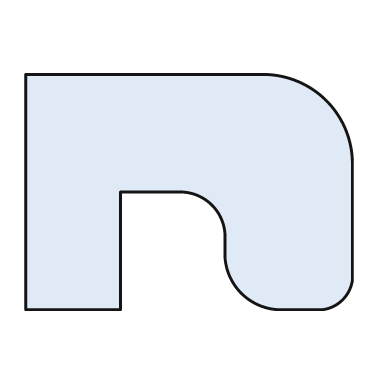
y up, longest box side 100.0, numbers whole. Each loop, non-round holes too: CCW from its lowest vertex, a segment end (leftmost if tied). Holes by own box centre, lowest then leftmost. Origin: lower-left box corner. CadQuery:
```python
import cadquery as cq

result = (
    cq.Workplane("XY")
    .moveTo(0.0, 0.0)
    .lineTo(29.0, 0.0)
    .lineTo(29.0, 36.0)
    .lineTo(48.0, 36.0)
    .threePointArc((57.0, 32.0), (61.0, 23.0))
    .lineTo(61.0, 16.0)
    .threePointArc((66.0, 5.0), (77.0, 0.0))
    .lineTo(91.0, 0.0)
    .threePointArc((97.0, 3.0), (100.0, 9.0))
    .lineTo(100.0, 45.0)
    .threePointArc((92.0, 64.0), (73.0, 72.0))
    .lineTo(0.0, 72.0)
    .close()
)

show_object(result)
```